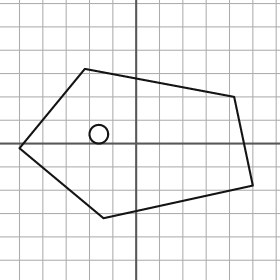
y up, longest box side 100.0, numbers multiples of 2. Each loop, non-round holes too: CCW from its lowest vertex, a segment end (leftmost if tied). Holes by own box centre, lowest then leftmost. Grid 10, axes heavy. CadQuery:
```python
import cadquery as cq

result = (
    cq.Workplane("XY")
    .moveTo(-14.0, -32.0)
    .lineTo(50.0, -18.0)
    .lineTo(42.0, 20.0)
    .lineTo(-22.0, 32.0)
    .lineTo(-50.0, -2.0)
    .close()
    .moveTo(-16.0, 4.0)
    .circle(4.0)
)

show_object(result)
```